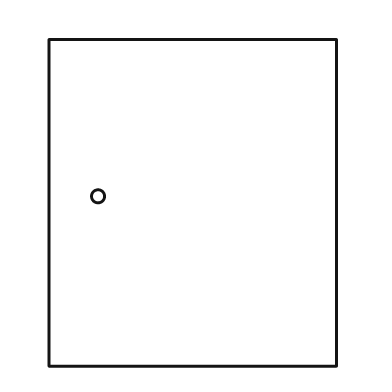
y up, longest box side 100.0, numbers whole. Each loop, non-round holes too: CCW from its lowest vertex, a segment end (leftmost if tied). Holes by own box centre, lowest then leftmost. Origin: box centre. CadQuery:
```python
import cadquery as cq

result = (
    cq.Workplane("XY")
    .moveTo(-44.0, -50.0)
    .lineTo(44.0, -50.0)
    .lineTo(44.0, 50.0)
    .lineTo(-44.0, 50.0)
    .close()
    .moveTo(-29.0, 2.0)
    .circle(2.0)
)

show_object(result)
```